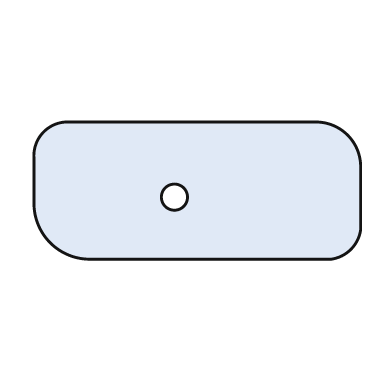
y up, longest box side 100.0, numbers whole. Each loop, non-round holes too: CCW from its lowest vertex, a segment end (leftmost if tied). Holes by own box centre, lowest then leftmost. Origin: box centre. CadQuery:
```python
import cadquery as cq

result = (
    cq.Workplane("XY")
    .moveTo(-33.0, -21.0)
    .lineTo(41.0, -21.0)
    .threePointArc((47.0, -18.0), (50.0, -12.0))
    .lineTo(50.0, 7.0)
    .threePointArc((46.0, 17.0), (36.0, 21.0))
    .lineTo(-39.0, 21.0)
    .threePointArc((-47.0, 18.0), (-50.0, 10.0))
    .lineTo(-50.0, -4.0)
    .threePointArc((-45.0, -16.0), (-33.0, -21.0))
    .close()
    .moveTo(-7.0, -2.0)
    .circle(4.0)
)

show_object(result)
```